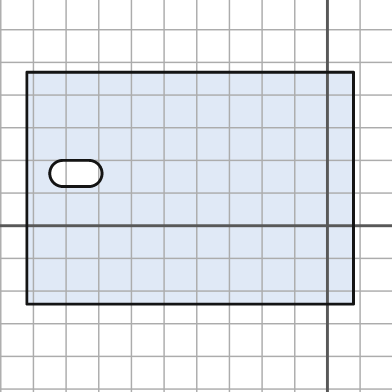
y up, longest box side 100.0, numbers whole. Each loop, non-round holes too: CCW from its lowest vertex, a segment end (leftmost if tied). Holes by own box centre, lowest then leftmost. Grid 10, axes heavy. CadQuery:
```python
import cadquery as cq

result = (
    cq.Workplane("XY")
    .moveTo(-92.0, -24.0)
    .lineTo(8.0, -24.0)
    .lineTo(8.0, 47.0)
    .lineTo(-92.0, 47.0)
    .close()
    .moveTo(-81.0, 12.0)
    .lineTo(-73.0, 12.0)
    .threePointArc((-69.0, 16.0), (-73.0, 20.0))
    .lineTo(-81.0, 20.0)
    .threePointArc((-85.0, 16.0), (-81.0, 12.0))
    .close()
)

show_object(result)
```